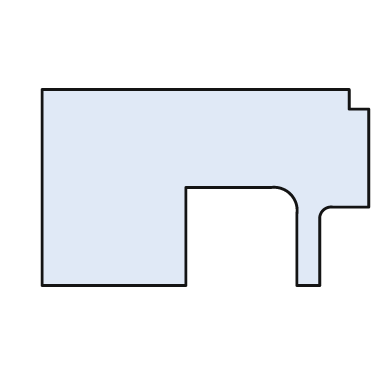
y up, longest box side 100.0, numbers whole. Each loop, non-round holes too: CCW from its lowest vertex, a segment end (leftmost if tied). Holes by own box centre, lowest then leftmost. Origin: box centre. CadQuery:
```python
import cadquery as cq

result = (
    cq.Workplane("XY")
    .moveTo(-50.0, -30.0)
    .lineTo(-6.0, -30.0)
    .lineTo(-6.0, 0.0)
    .lineTo(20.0, 0.0)
    .threePointArc((26.0, -2.0), (28.0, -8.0))
    .lineTo(28.0, -30.0)
    .lineTo(35.0, -30.0)
    .lineTo(35.0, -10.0)
    .threePointArc((36.0, -7.0), (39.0, -6.0))
    .lineTo(50.0, -6.0)
    .lineTo(50.0, 24.0)
    .lineTo(44.0, 24.0)
    .lineTo(44.0, 30.0)
    .lineTo(-50.0, 30.0)
    .close()
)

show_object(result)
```